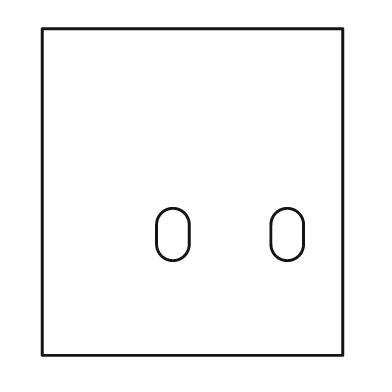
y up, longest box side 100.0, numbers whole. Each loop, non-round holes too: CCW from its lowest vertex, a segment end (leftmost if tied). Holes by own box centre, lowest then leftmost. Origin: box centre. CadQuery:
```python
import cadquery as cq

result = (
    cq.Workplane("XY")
    .moveTo(-46.0, -50.0)
    .lineTo(46.0, -50.0)
    .lineTo(46.0, 50.0)
    .lineTo(-46.0, 50.0)
    .close()
    .moveTo(-11.0, -16.0)
    .threePointArc((-6.0, -21.0), (-1.0, -16.0))
    .lineTo(-1.0, -10.0)
    .threePointArc((-6.0, -5.0), (-11.0, -10.0))
    .close()
    .moveTo(24.0, -16.0)
    .threePointArc((29.0, -21.0), (34.0, -16.0))
    .lineTo(34.0, -10.0)
    .threePointArc((29.0, -5.0), (24.0, -10.0))
    .close()
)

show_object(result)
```